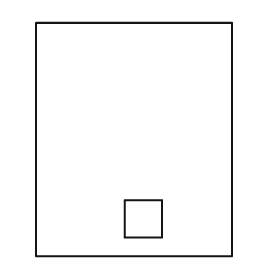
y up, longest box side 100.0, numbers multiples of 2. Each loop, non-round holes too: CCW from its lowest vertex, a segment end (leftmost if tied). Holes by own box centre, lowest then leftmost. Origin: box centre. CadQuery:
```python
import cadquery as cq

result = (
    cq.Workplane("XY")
    .moveTo(-42.0, -50.0)
    .lineTo(42.0, -50.0)
    .lineTo(42.0, 50.0)
    .lineTo(-42.0, 50.0)
    .close()
    .moveTo(-4.0, -42.0)
    .lineTo(12.0, -42.0)
    .lineTo(12.0, -26.0)
    .lineTo(-4.0, -26.0)
    .close()
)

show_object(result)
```